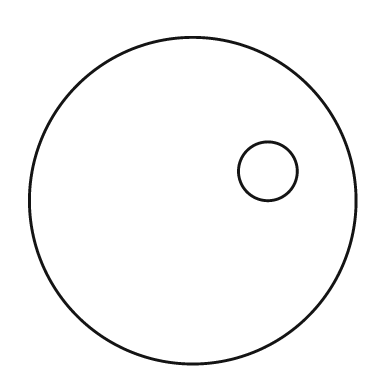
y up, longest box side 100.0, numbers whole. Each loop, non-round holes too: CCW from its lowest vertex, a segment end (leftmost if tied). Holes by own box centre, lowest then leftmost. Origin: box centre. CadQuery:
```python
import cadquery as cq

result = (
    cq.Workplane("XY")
    .moveTo(0.0, 0.0)
    .circle(50.0)
    .moveTo(23.0, 9.0)
    .circle(9.0)
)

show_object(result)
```